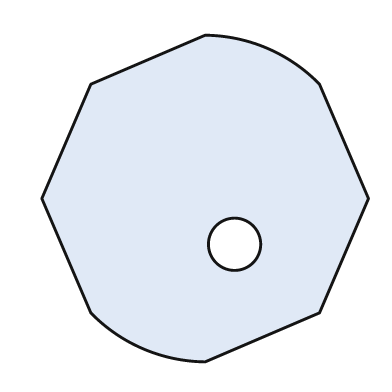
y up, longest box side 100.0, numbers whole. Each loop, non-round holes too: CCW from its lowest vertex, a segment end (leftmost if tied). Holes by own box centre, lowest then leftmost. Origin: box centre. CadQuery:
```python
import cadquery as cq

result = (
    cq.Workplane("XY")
    .moveTo(0.0, -50.0)
    .lineTo(35.0, -35.0)
    .lineTo(50.0, 0.0)
    .lineTo(35.0, 35.0)
    .threePointArc((19.0, 46.0), (0.0, 50.0))
    .lineTo(-35.0, 35.0)
    .lineTo(-50.0, 0.0)
    .lineTo(-35.0, -35.0)
    .threePointArc((-19.0, -46.0), (0.0, -50.0))
    .close()
    .moveTo(9.0, -14.0)
    .circle(8.0)
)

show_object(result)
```